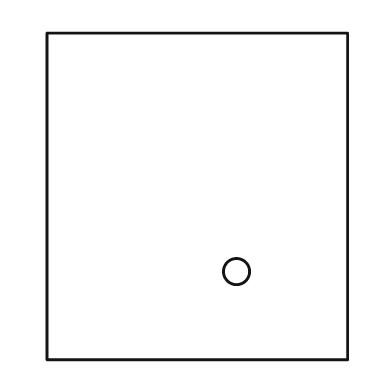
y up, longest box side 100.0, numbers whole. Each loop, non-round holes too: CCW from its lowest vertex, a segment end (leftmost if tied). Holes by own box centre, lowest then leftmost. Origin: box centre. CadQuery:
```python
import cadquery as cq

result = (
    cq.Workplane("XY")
    .moveTo(-46.0, -50.0)
    .lineTo(46.0, -50.0)
    .lineTo(46.0, 50.0)
    .lineTo(-46.0, 50.0)
    .close()
    .moveTo(12.0, -23.0)
    .circle(4.0)
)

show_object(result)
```